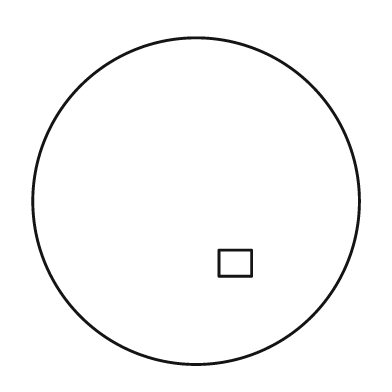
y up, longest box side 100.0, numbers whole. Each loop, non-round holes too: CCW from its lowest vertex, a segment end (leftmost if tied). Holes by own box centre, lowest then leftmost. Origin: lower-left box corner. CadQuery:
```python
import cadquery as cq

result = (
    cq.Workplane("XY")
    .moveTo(50.0, 50.0)
    .circle(50.0)
    .moveTo(57.0, 27.0)
    .lineTo(67.0, 27.0)
    .lineTo(67.0, 35.0)
    .lineTo(57.0, 35.0)
    .close()
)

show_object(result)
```